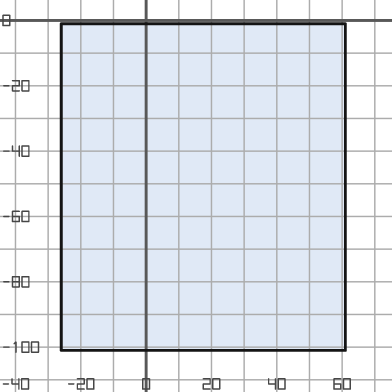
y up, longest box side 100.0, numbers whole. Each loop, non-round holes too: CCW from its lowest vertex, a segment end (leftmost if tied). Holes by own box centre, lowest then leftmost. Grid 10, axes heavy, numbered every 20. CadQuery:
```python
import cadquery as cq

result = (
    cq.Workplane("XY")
    .moveTo(-26.0, -101.0)
    .lineTo(61.0, -101.0)
    .lineTo(61.0, -1.0)
    .lineTo(-26.0, -1.0)
    .close()
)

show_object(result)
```